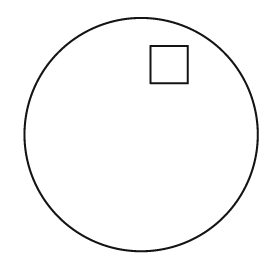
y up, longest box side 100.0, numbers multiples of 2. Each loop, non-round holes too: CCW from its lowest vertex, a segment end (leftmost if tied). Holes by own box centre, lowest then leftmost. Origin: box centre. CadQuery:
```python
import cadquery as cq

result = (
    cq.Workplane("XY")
    .moveTo(0.0, 0.0)
    .circle(50.0)
    .moveTo(4.0, 22.0)
    .lineTo(20.0, 22.0)
    .lineTo(20.0, 38.0)
    .lineTo(4.0, 38.0)
    .close()
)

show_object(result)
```